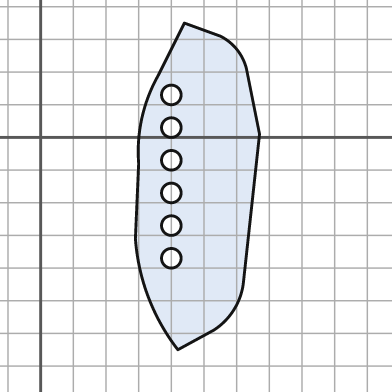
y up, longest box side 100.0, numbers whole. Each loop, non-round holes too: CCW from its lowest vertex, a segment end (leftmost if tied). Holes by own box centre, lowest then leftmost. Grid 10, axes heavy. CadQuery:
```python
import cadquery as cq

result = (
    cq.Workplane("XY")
    .moveTo(42.0, -65.0)
    .lineTo(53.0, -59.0)
    .threePointArc((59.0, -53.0), (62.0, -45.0))
    .lineTo(67.0, 1.0)
    .lineTo(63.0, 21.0)
    .threePointArc((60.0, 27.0), (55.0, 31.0))
    .lineTo(44.0, 35.0)
    .lineTo(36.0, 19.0)
    .threePointArc((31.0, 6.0), (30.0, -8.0))
    .lineTo(29.0, -31.0)
    .threePointArc((33.0, -49.0), (42.0, -65.0))
    .close()
    .moveTo(40.0, -37.0)
    .circle(3.0)
    .moveTo(40.0, -27.0)
    .circle(3.0)
    .moveTo(40.0, -17.0)
    .circle(3.0)
    .moveTo(40.0, -7.0)
    .circle(3.0)
    .moveTo(40.0, 3.0)
    .circle(3.0)
    .moveTo(40.0, 13.0)
    .circle(3.0)
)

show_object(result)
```